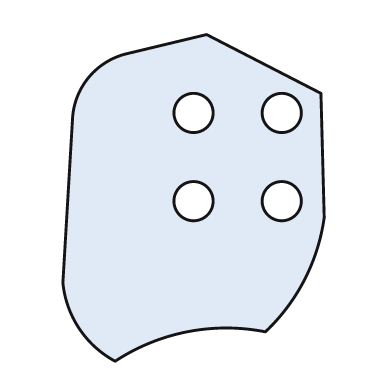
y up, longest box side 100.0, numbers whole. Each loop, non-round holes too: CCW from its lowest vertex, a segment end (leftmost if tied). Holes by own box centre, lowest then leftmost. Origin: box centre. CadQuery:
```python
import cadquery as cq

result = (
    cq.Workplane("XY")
    .moveTo(-24.0, -50.0)
    .threePointArc((-2.0, -41.0), (22.0, -41.0))
    .threePointArc((34.0, -25.0), (40.0, -6.0))
    .lineTo(39.0, 32.0)
    .lineTo(4.0, 50.0)
    .lineTo(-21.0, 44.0)
    .threePointArc((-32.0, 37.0), (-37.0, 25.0))
    .lineTo(-40.0, -26.0)
    .threePointArc((-35.0, -40.0), (-24.0, -50.0))
    .close()
    .moveTo(0.0, -1.0)
    .circle(6.0)
    .moveTo(27.0, -1.0)
    .circle(6.0)
    .moveTo(0.0, 26.0)
    .circle(6.0)
    .moveTo(27.0, 26.0)
    .circle(6.0)
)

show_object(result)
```